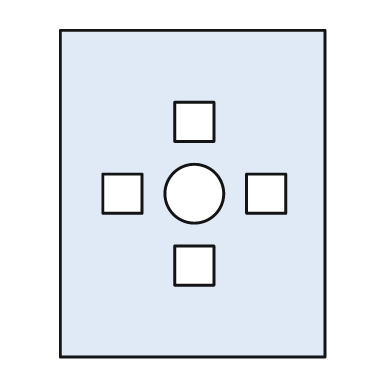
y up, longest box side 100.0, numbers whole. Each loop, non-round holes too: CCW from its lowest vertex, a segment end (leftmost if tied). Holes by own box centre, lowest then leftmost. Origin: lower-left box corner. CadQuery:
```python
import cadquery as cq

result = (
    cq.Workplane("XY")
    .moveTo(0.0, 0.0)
    .lineTo(81.0, 0.0)
    .lineTo(81.0, 100.0)
    .lineTo(0.0, 100.0)
    .close()
    .moveTo(35.0, 22.0)
    .lineTo(47.0, 22.0)
    .lineTo(47.0, 34.0)
    .lineTo(35.0, 34.0)
    .close()
    .moveTo(13.0, 44.0)
    .lineTo(25.0, 44.0)
    .lineTo(25.0, 56.0)
    .lineTo(13.0, 56.0)
    .close()
    .moveTo(41.0, 50.0)
    .circle(9.0)
    .moveTo(57.0, 44.0)
    .lineTo(69.0, 44.0)
    .lineTo(69.0, 56.0)
    .lineTo(57.0, 56.0)
    .close()
    .moveTo(35.0, 66.0)
    .lineTo(47.0, 66.0)
    .lineTo(47.0, 78.0)
    .lineTo(35.0, 78.0)
    .close()
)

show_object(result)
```